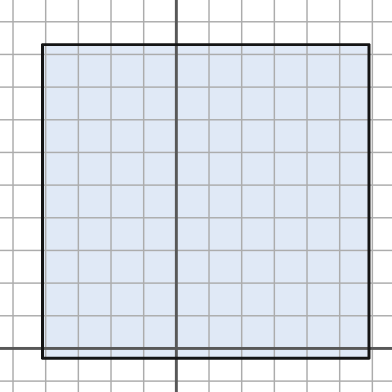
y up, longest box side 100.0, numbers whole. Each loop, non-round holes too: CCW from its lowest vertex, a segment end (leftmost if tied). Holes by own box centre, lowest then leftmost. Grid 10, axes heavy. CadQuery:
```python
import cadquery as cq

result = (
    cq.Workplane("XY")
    .moveTo(-41.0, -3.0)
    .lineTo(59.0, -3.0)
    .lineTo(59.0, 93.0)
    .lineTo(-41.0, 93.0)
    .close()
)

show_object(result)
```